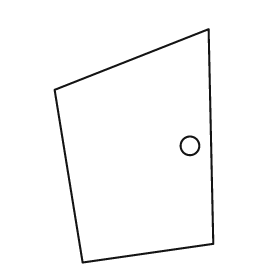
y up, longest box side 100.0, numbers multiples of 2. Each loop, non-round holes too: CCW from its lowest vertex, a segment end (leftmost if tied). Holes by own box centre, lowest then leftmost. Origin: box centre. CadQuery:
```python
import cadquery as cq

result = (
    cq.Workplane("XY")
    .moveTo(-22.0, -50.0)
    .lineTo(34.0, -42.0)
    .lineTo(32.0, 50.0)
    .lineTo(-34.0, 24.0)
    .close()
    .moveTo(24.0, 0.0)
    .circle(4.0)
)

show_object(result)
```